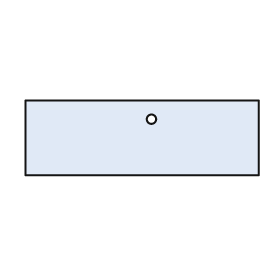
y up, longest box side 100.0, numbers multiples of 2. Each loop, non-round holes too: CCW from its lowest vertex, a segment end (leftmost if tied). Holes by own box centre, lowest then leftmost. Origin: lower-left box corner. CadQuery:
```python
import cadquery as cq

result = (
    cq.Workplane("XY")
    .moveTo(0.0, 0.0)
    .lineTo(100.0, 0.0)
    .lineTo(100.0, 32.0)
    .lineTo(0.0, 32.0)
    .close()
    .moveTo(54.0, 24.0)
    .circle(2.0)
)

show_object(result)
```